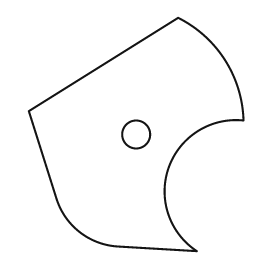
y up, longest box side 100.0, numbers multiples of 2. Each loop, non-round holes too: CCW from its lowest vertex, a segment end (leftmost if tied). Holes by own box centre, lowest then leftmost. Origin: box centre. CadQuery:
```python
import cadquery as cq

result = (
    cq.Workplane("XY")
    .moveTo(26.0, -50.0)
    .threePointArc((14.0, -14.0), (46.0, 6.0))
    .threePointArc((38.0, 32.0), (18.0, 50.0))
    .lineTo(-46.0, 10.0)
    .lineTo(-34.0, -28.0)
    .threePointArc((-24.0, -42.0), (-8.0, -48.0))
    .close()
    .moveTo(0.0, 0.0)
    .circle(6.0)
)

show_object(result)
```